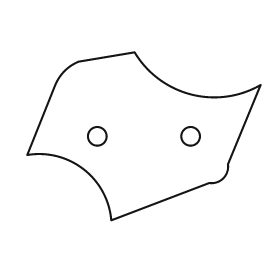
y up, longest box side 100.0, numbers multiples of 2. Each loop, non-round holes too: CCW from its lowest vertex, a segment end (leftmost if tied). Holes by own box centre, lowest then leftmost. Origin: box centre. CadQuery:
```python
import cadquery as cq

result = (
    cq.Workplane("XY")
    .moveTo(-14.0, -36.0)
    .lineTo(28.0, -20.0)
    .threePointArc((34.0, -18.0), (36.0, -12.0))
    .lineTo(50.0, 22.0)
    .threePointArc((20.0, 18.0), (-4.0, 36.0))
    .lineTo(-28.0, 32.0)
    .threePointArc((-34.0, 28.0), (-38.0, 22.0))
    .lineTo(-50.0, -8.0)
    .threePointArc((-26.0, -14.0), (-14.0, -36.0))
    .close()
    .moveTo(-20.0, 0.0)
    .circle(4.0)
    .moveTo(20.0, 0.0)
    .circle(4.0)
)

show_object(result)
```